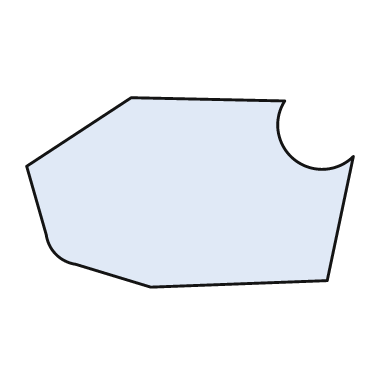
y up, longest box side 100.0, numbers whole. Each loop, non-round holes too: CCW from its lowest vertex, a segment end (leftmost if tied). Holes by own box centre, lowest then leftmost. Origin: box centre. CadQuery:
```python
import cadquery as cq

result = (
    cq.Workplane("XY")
    .moveTo(-12.0, -29.0)
    .lineTo(42.0, -27.0)
    .lineTo(50.0, 11.0)
    .threePointArc((32.0, 10.0), (29.0, 28.0))
    .lineTo(-18.0, 29.0)
    .lineTo(-50.0, 8.0)
    .lineTo(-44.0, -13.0)
    .threePointArc((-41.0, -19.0), (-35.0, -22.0))
    .close()
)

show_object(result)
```